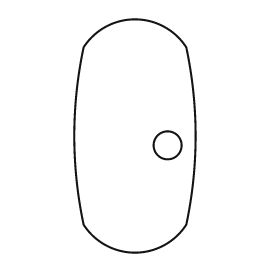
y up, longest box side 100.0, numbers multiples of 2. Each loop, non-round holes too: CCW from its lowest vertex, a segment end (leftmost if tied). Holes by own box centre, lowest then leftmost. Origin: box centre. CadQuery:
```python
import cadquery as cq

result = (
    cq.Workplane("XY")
    .moveTo(-22.0, -38.0)
    .threePointArc((0.0, -50.0), (22.0, -38.0))
    .threePointArc((26.0, 0.0), (22.0, 38.0))
    .threePointArc((0.0, 50.0), (-22.0, 38.0))
    .threePointArc((-26.0, 0.0), (-22.0, -38.0))
    .close()
    .moveTo(14.0, -4.0)
    .circle(6.0)
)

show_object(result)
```